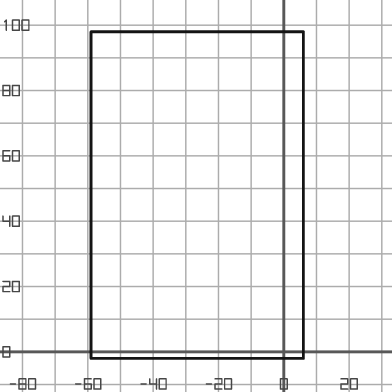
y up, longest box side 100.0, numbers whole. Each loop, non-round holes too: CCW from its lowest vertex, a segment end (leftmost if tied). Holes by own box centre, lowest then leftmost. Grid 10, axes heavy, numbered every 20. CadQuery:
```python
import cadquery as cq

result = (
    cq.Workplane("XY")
    .moveTo(-59.0, -2.0)
    .lineTo(6.0, -2.0)
    .lineTo(6.0, 98.0)
    .lineTo(-59.0, 98.0)
    .close()
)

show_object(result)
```